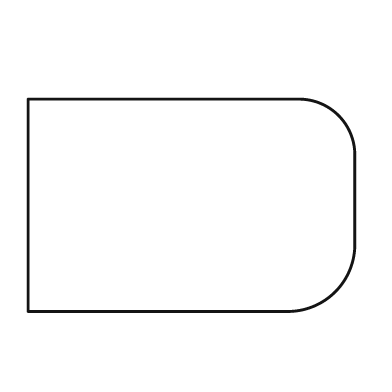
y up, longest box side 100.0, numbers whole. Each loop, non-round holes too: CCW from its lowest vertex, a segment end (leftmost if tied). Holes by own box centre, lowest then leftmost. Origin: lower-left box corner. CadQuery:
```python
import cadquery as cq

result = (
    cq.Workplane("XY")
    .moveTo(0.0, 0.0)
    .lineTo(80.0, 0.0)
    .threePointArc((94.0, 6.0), (100.0, 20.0))
    .lineTo(100.0, 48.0)
    .threePointArc((95.0, 60.0), (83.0, 65.0))
    .lineTo(0.0, 65.0)
    .close()
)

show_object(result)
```